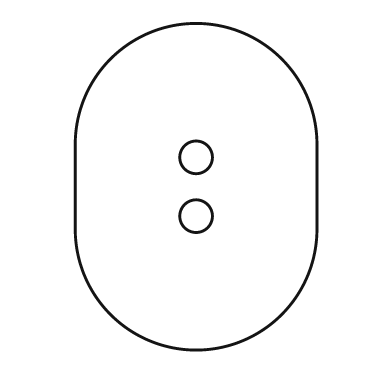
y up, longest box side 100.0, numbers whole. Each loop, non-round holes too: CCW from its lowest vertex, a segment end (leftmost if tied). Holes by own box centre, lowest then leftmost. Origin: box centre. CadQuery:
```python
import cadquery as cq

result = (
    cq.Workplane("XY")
    .moveTo(-37.0, -13.0)
    .threePointArc((0.0, -50.0), (37.0, -13.0))
    .lineTo(37.0, 13.0)
    .threePointArc((0.0, 50.0), (-37.0, 13.0))
    .close()
    .moveTo(0.0, -9.0)
    .circle(5.0)
    .moveTo(0.0, 9.0)
    .circle(5.0)
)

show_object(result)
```